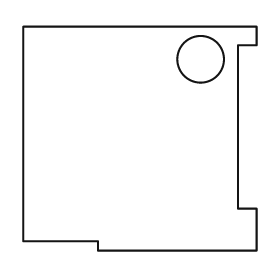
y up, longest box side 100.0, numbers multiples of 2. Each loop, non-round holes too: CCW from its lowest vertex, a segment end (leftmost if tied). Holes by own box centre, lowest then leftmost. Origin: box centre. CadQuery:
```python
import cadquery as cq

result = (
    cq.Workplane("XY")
    .moveTo(-18.0, -48.0)
    .lineTo(50.0, -48.0)
    .lineTo(50.0, -30.0)
    .lineTo(42.0, -30.0)
    .lineTo(42.0, 40.0)
    .lineTo(50.0, 40.0)
    .lineTo(50.0, 48.0)
    .lineTo(-50.0, 48.0)
    .lineTo(-50.0, -44.0)
    .lineTo(-18.0, -44.0)
    .close()
    .moveTo(26.0, 34.0)
    .circle(10.0)
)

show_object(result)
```